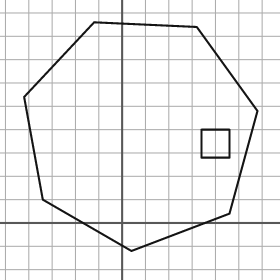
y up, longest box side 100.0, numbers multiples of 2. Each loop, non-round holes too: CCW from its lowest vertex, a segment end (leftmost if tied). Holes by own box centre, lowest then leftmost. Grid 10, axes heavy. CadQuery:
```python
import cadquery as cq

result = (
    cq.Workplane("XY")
    .moveTo(4.0, -12.0)
    .lineTo(46.0, 4.0)
    .lineTo(58.0, 48.0)
    .lineTo(32.0, 84.0)
    .lineTo(-12.0, 86.0)
    .lineTo(-42.0, 54.0)
    .lineTo(-34.0, 10.0)
    .close()
    .moveTo(34.0, 28.0)
    .lineTo(46.0, 28.0)
    .lineTo(46.0, 40.0)
    .lineTo(34.0, 40.0)
    .close()
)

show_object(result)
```